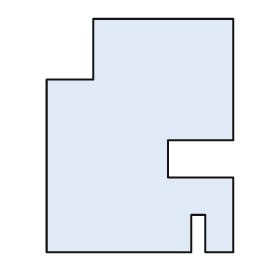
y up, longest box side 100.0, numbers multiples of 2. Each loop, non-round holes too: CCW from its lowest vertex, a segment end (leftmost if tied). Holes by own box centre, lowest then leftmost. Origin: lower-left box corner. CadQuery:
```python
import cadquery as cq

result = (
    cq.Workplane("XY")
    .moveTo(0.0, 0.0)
    .lineTo(62.0, 0.0)
    .lineTo(62.0, 16.0)
    .lineTo(68.0, 16.0)
    .lineTo(68.0, 0.0)
    .lineTo(80.0, 0.0)
    .lineTo(80.0, 32.0)
    .lineTo(52.0, 32.0)
    .lineTo(52.0, 48.0)
    .lineTo(80.0, 48.0)
    .lineTo(80.0, 100.0)
    .lineTo(20.0, 100.0)
    .lineTo(20.0, 74.0)
    .lineTo(0.0, 74.0)
    .close()
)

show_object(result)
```